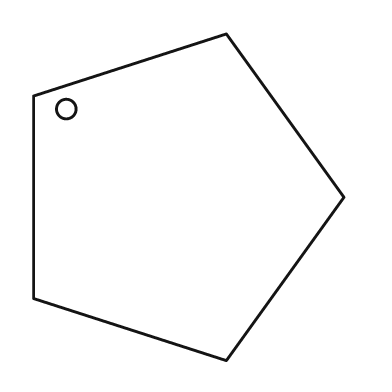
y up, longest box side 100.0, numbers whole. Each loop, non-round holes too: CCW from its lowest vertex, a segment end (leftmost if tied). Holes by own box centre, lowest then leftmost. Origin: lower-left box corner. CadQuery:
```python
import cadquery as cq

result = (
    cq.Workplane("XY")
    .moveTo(59.0, 0.0)
    .lineTo(95.0, 50.0)
    .lineTo(59.0, 100.0)
    .lineTo(0.0, 81.0)
    .lineTo(0.0, 19.0)
    .close()
    .moveTo(10.0, 77.0)
    .circle(3.0)
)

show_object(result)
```